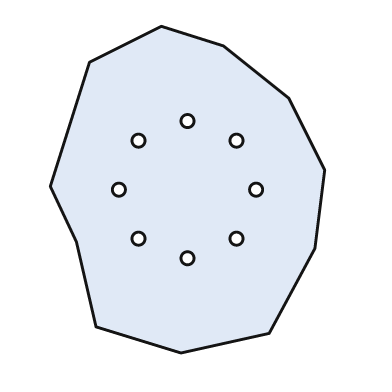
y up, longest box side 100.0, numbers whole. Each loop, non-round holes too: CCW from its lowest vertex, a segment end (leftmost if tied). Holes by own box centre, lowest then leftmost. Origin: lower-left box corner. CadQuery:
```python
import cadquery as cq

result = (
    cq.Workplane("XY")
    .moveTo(40.0, 0.0)
    .lineTo(67.0, 6.0)
    .lineTo(81.0, 32.0)
    .lineTo(84.0, 56.0)
    .lineTo(73.0, 78.0)
    .lineTo(53.0, 94.0)
    .lineTo(34.0, 100.0)
    .lineTo(12.0, 89.0)
    .lineTo(0.0, 51.0)
    .lineTo(8.0, 34.0)
    .lineTo(14.0, 8.0)
    .close()
    .moveTo(42.0, 29.0)
    .circle(2.0)
    .moveTo(27.0, 35.0)
    .circle(2.0)
    .moveTo(57.0, 35.0)
    .circle(2.0)
    .moveTo(21.0, 50.0)
    .circle(2.0)
    .moveTo(63.0, 50.0)
    .circle(2.0)
    .moveTo(27.0, 65.0)
    .circle(2.0)
    .moveTo(57.0, 65.0)
    .circle(2.0)
    .moveTo(42.0, 71.0)
    .circle(2.0)
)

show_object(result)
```